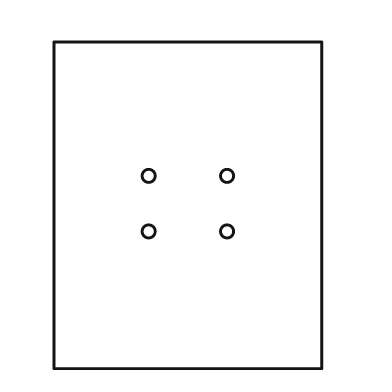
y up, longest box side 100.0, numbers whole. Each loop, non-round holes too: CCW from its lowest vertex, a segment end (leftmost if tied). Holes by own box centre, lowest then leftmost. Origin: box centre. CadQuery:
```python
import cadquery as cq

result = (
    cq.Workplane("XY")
    .moveTo(-41.0, -50.0)
    .lineTo(41.0, -50.0)
    .lineTo(41.0, 50.0)
    .lineTo(-41.0, 50.0)
    .close()
    .moveTo(-12.0, -8.0)
    .circle(2.0)
    .moveTo(12.0, -8.0)
    .circle(2.0)
    .moveTo(-12.0, 9.0)
    .circle(2.0)
    .moveTo(12.0, 9.0)
    .circle(2.0)
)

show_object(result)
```